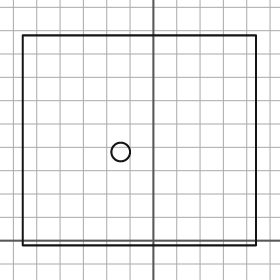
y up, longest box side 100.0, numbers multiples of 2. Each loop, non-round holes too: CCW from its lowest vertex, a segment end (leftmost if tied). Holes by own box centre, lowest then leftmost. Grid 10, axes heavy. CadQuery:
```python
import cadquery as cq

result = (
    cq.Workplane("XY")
    .moveTo(-56.0, -2.0)
    .lineTo(44.0, -2.0)
    .lineTo(44.0, 88.0)
    .lineTo(-56.0, 88.0)
    .close()
    .moveTo(-14.0, 38.0)
    .circle(4.0)
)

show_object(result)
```